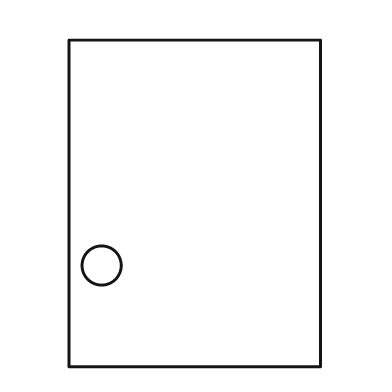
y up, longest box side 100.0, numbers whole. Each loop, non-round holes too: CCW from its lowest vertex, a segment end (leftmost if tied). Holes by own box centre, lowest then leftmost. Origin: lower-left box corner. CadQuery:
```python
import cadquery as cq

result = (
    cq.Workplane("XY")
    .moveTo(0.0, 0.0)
    .lineTo(77.0, 0.0)
    .lineTo(77.0, 100.0)
    .lineTo(0.0, 100.0)
    .close()
    .moveTo(10.0, 31.0)
    .circle(6.0)
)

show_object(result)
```